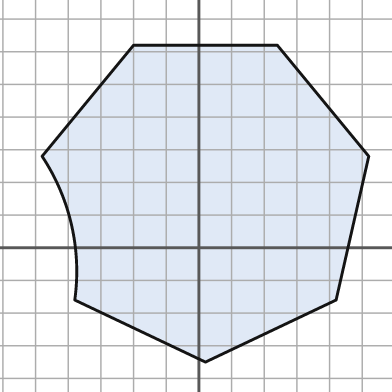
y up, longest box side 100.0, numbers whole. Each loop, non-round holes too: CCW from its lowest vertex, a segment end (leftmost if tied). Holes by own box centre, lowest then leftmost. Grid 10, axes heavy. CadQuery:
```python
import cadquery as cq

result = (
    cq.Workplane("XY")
    .moveTo(2.0, -35.0)
    .lineTo(42.0, -16.0)
    .lineTo(52.0, 28.0)
    .lineTo(24.0, 62.0)
    .lineTo(-20.0, 62.0)
    .lineTo(-48.0, 28.0)
    .threePointArc((-39.0, 7.0), (-38.0, -16.0))
    .close()
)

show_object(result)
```